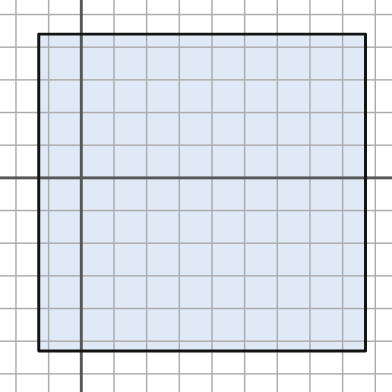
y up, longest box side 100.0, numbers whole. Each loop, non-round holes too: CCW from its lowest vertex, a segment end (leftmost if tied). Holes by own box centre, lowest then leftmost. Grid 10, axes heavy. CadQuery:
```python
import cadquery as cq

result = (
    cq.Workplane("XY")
    .moveTo(-13.0, -53.0)
    .lineTo(87.0, -53.0)
    .lineTo(87.0, 44.0)
    .lineTo(-13.0, 44.0)
    .close()
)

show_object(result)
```